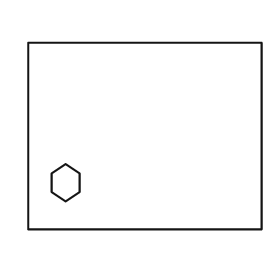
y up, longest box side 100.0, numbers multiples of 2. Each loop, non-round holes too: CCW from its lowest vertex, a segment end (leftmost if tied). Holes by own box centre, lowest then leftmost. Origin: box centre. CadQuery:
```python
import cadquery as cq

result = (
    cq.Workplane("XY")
    .moveTo(-50.0, -40.0)
    .lineTo(50.0, -40.0)
    .lineTo(50.0, 40.0)
    .lineTo(-50.0, 40.0)
    .close()
    .moveTo(-34.0, -28.0)
    .lineTo(-28.0, -24.0)
    .lineTo(-28.0, -16.0)
    .lineTo(-34.0, -12.0)
    .lineTo(-40.0, -16.0)
    .lineTo(-40.0, -24.0)
    .close()
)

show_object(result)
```